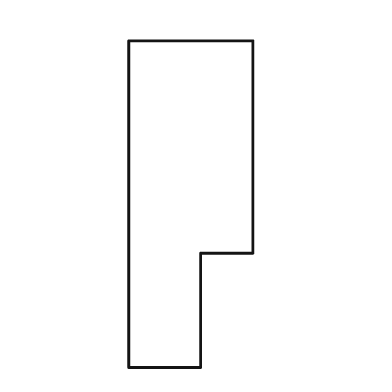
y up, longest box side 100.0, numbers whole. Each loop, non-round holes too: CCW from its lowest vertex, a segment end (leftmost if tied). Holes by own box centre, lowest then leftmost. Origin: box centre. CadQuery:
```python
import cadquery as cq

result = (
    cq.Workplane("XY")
    .moveTo(-19.0, -50.0)
    .lineTo(3.0, -50.0)
    .lineTo(3.0, -15.0)
    .lineTo(19.0, -15.0)
    .lineTo(19.0, 50.0)
    .lineTo(-19.0, 50.0)
    .close()
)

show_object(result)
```